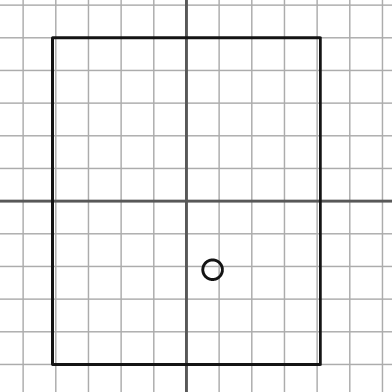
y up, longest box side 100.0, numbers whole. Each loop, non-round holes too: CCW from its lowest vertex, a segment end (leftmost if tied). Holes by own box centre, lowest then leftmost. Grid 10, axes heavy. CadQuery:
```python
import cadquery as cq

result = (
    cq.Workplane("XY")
    .moveTo(-41.0, -50.0)
    .lineTo(41.0, -50.0)
    .lineTo(41.0, 50.0)
    .lineTo(-41.0, 50.0)
    .close()
    .moveTo(8.0, -21.0)
    .circle(3.0)
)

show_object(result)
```